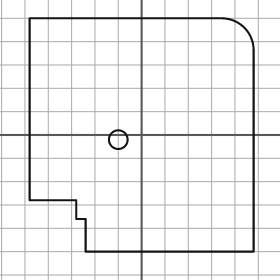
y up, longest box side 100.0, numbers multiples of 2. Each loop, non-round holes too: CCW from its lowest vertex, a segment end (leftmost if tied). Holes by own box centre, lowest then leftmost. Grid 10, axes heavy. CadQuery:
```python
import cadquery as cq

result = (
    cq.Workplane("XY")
    .moveTo(-24.0, -50.0)
    .lineTo(48.0, -50.0)
    .lineTo(48.0, 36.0)
    .threePointArc((44.0, 46.0), (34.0, 50.0))
    .lineTo(-48.0, 50.0)
    .lineTo(-48.0, -28.0)
    .lineTo(-28.0, -28.0)
    .lineTo(-28.0, -36.0)
    .lineTo(-24.0, -36.0)
    .close()
    .moveTo(-10.0, -2.0)
    .circle(4.0)
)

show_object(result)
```